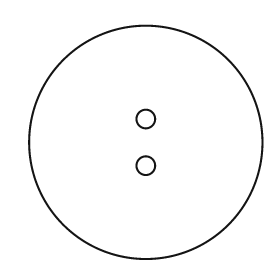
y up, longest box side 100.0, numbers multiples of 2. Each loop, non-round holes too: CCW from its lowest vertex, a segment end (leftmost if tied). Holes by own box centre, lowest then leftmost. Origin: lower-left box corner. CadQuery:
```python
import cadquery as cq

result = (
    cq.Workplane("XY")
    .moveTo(50.0, 50.0)
    .circle(50.0)
    .moveTo(50.0, 40.0)
    .circle(4.0)
    .moveTo(50.0, 60.0)
    .circle(4.0)
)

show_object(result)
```